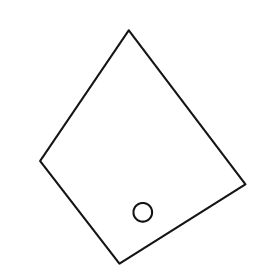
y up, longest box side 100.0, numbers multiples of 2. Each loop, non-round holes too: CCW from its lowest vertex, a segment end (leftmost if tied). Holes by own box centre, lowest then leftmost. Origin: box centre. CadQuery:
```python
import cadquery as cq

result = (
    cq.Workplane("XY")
    .moveTo(-10.0, -50.0)
    .lineTo(44.0, -16.0)
    .lineTo(-6.0, 50.0)
    .lineTo(-44.0, -6.0)
    .close()
    .moveTo(0.0, -28.0)
    .circle(4.0)
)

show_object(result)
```